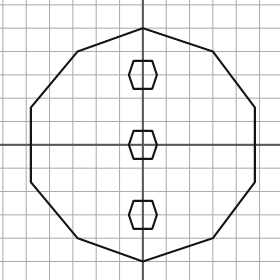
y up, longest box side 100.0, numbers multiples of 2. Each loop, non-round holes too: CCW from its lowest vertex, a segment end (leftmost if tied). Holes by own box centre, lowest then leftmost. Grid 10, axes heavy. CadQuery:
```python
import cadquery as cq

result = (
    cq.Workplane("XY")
    .moveTo(0.0, -50.0)
    .lineTo(30.0, -40.0)
    .lineTo(48.0, -16.0)
    .lineTo(48.0, 16.0)
    .lineTo(30.0, 40.0)
    .lineTo(0.0, 50.0)
    .lineTo(-28.0, 40.0)
    .lineTo(-48.0, 16.0)
    .lineTo(-48.0, -16.0)
    .lineTo(-28.0, -40.0)
    .close()
    .moveTo(-4.0, -36.0)
    .lineTo(4.0, -36.0)
    .lineTo(6.0, -30.0)
    .lineTo(4.0, -24.0)
    .lineTo(-4.0, -24.0)
    .lineTo(-6.0, -30.0)
    .close()
    .moveTo(-4.0, -6.0)
    .lineTo(4.0, -6.0)
    .lineTo(6.0, 0.0)
    .lineTo(4.0, 6.0)
    .lineTo(-4.0, 6.0)
    .lineTo(-6.0, 0.0)
    .close()
    .moveTo(-4.0, 24.0)
    .lineTo(4.0, 24.0)
    .lineTo(6.0, 30.0)
    .lineTo(4.0, 36.0)
    .lineTo(-4.0, 36.0)
    .lineTo(-6.0, 30.0)
    .close()
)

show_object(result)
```